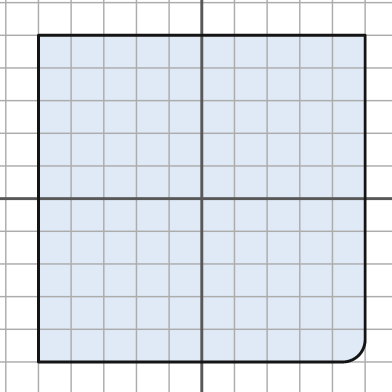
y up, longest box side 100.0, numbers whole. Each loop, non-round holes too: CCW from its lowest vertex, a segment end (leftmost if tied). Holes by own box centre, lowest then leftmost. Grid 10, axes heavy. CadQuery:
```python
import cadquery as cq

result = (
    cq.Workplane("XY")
    .moveTo(-50.0, -50.0)
    .lineTo(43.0, -50.0)
    .threePointArc((48.0, -48.0), (50.0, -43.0))
    .lineTo(50.0, 50.0)
    .lineTo(-50.0, 50.0)
    .close()
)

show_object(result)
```